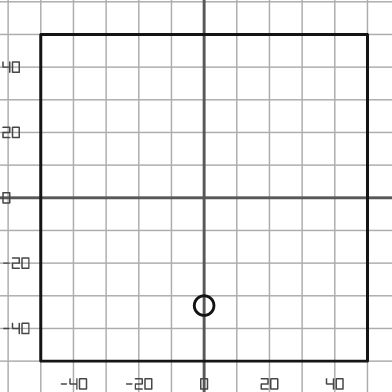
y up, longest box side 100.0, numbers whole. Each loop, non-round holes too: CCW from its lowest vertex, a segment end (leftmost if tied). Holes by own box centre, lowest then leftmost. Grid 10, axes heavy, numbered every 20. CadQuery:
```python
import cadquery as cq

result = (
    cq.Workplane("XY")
    .moveTo(-50.0, -50.0)
    .lineTo(50.0, -50.0)
    .lineTo(50.0, 50.0)
    .lineTo(-50.0, 50.0)
    .close()
    .moveTo(0.0, -33.0)
    .circle(3.0)
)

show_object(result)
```